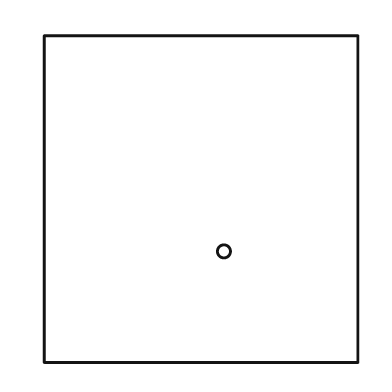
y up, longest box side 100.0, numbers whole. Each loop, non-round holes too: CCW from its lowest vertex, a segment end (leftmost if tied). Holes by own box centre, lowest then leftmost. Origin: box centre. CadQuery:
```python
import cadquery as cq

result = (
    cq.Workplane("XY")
    .moveTo(-48.0, -50.0)
    .lineTo(48.0, -50.0)
    .lineTo(48.0, 50.0)
    .lineTo(-48.0, 50.0)
    .close()
    .moveTo(7.0, -16.0)
    .circle(2.0)
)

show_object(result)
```